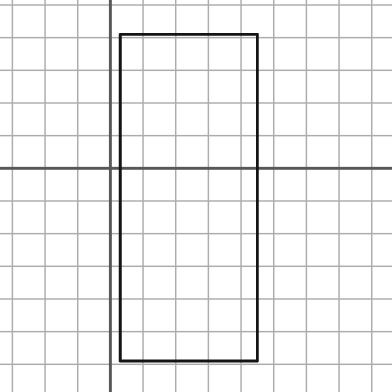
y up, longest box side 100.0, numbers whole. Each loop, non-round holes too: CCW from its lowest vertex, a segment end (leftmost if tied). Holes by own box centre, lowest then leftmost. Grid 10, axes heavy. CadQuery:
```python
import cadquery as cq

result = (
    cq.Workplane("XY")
    .moveTo(3.0, -59.0)
    .lineTo(45.0, -59.0)
    .lineTo(45.0, 41.0)
    .lineTo(3.0, 41.0)
    .close()
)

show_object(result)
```